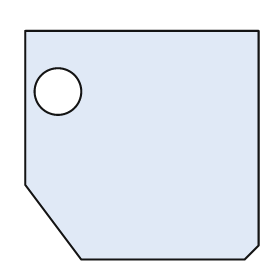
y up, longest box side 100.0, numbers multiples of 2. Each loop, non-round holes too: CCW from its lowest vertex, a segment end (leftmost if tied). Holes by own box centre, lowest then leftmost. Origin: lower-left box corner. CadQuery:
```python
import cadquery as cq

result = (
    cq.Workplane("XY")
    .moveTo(24.0, 0.0)
    .lineTo(94.0, 0.0)
    .lineTo(100.0, 6.0)
    .lineTo(100.0, 98.0)
    .lineTo(0.0, 98.0)
    .lineTo(0.0, 32.0)
    .close()
    .moveTo(14.0, 72.0)
    .circle(10.0)
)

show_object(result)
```